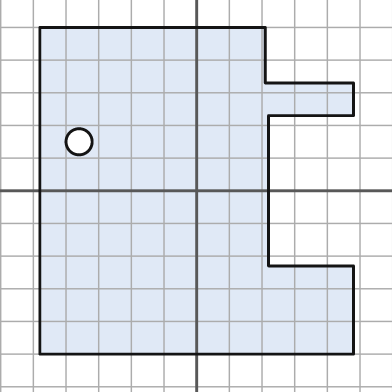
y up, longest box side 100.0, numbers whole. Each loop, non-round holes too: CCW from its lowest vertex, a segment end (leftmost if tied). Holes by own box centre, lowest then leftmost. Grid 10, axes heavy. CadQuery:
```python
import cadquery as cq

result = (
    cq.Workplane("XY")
    .moveTo(-48.0, -50.0)
    .lineTo(48.0, -50.0)
    .lineTo(48.0, -23.0)
    .lineTo(22.0, -23.0)
    .lineTo(22.0, 23.0)
    .lineTo(48.0, 23.0)
    .lineTo(48.0, 33.0)
    .lineTo(21.0, 33.0)
    .lineTo(21.0, 50.0)
    .lineTo(-48.0, 50.0)
    .close()
    .moveTo(-36.0, 15.0)
    .circle(4.0)
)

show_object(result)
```